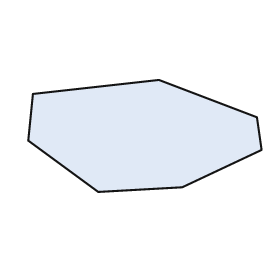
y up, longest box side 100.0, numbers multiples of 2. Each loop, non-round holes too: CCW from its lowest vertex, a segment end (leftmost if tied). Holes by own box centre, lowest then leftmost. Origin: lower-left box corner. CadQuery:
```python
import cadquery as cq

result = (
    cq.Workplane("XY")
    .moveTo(30.0, 0.0)
    .lineTo(66.0, 2.0)
    .lineTo(100.0, 18.0)
    .lineTo(98.0, 32.0)
    .lineTo(56.0, 48.0)
    .lineTo(2.0, 42.0)
    .lineTo(0.0, 22.0)
    .close()
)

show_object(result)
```